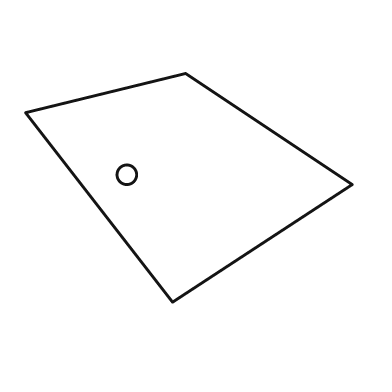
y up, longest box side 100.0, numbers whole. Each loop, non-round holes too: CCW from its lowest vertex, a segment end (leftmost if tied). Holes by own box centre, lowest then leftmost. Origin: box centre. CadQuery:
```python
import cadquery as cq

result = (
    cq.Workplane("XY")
    .moveTo(-5.0, -35.0)
    .lineTo(50.0, 1.0)
    .lineTo(-1.0, 35.0)
    .lineTo(-50.0, 23.0)
    .close()
    .moveTo(-19.0, 4.0)
    .circle(3.0)
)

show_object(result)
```